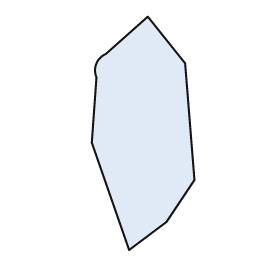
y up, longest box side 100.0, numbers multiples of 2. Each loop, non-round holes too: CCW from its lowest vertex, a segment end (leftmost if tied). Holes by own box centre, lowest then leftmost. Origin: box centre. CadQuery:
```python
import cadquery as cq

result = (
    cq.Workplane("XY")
    .moveTo(-6.0, -50.0)
    .lineTo(10.0, -38.0)
    .lineTo(22.0, -20.0)
    .lineTo(18.0, 30.0)
    .lineTo(2.0, 50.0)
    .lineTo(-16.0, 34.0)
    .threePointArc((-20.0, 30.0), (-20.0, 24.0))
    .lineTo(-22.0, -4.0)
    .close()
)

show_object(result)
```